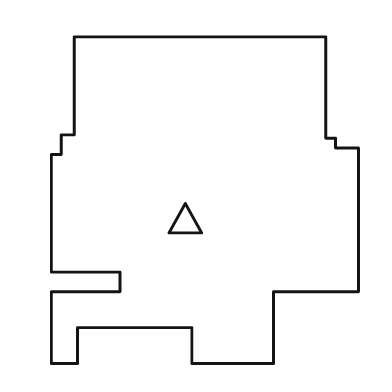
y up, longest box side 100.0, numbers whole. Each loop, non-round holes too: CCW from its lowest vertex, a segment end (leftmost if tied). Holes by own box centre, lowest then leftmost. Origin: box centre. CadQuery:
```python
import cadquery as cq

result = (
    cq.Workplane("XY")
    .moveTo(-47.0, -50.0)
    .lineTo(-39.0, -50.0)
    .lineTo(-39.0, -39.0)
    .lineTo(-4.0, -39.0)
    .lineTo(-4.0, -50.0)
    .lineTo(21.0, -50.0)
    .lineTo(21.0, -28.0)
    .lineTo(47.0, -28.0)
    .lineTo(47.0, 16.0)
    .lineTo(40.0, 16.0)
    .lineTo(40.0, 19.0)
    .lineTo(37.0, 19.0)
    .lineTo(37.0, 50.0)
    .lineTo(-40.0, 50.0)
    .lineTo(-40.0, 20.0)
    .lineTo(-44.0, 20.0)
    .lineTo(-44.0, 14.0)
    .lineTo(-47.0, 14.0)
    .lineTo(-47.0, -22.0)
    .lineTo(-26.0, -22.0)
    .lineTo(-26.0, -28.0)
    .lineTo(-47.0, -28.0)
    .close()
    .moveTo(-11.0, -10.0)
    .lineTo(-1.0, -10.0)
    .lineTo(-6.0, -1.0)
    .close()
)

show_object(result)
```